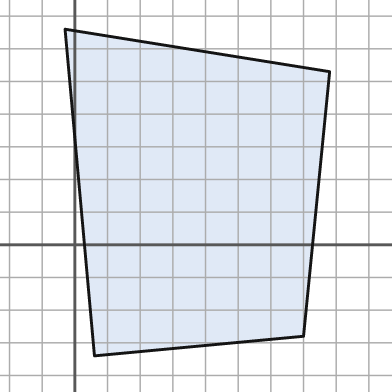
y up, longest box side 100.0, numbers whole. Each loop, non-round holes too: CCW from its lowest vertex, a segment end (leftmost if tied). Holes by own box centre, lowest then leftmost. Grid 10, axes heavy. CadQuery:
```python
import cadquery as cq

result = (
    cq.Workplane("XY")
    .moveTo(6.0, -34.0)
    .lineTo(70.0, -28.0)
    .lineTo(78.0, 53.0)
    .lineTo(-3.0, 66.0)
    .close()
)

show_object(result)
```